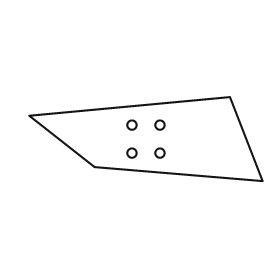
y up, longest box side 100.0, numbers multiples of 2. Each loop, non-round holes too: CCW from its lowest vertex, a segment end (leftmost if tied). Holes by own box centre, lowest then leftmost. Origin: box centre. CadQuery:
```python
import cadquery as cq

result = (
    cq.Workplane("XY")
    .moveTo(50.0, -18.0)
    .lineTo(36.0, 18.0)
    .lineTo(-50.0, 10.0)
    .lineTo(-22.0, -12.0)
    .close()
    .moveTo(-6.0, -6.0)
    .circle(2.0)
    .moveTo(6.0, -6.0)
    .circle(2.0)
    .moveTo(-6.0, 6.0)
    .circle(2.0)
    .moveTo(6.0, 6.0)
    .circle(2.0)
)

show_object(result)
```